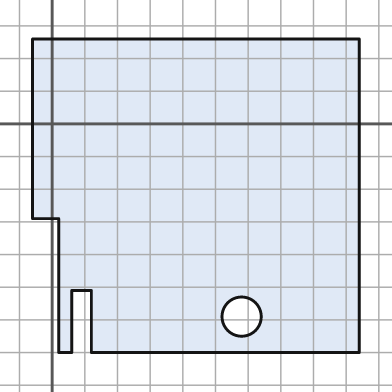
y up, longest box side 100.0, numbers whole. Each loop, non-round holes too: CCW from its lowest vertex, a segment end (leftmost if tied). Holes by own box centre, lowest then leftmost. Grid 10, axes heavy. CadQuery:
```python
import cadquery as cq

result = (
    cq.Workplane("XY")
    .moveTo(2.0, -70.0)
    .lineTo(6.0, -70.0)
    .lineTo(6.0, -51.0)
    .lineTo(12.0, -51.0)
    .lineTo(12.0, -70.0)
    .lineTo(94.0, -70.0)
    .lineTo(94.0, 26.0)
    .lineTo(-6.0, 26.0)
    .lineTo(-6.0, -29.0)
    .lineTo(2.0, -29.0)
    .close()
    .moveTo(58.0, -59.0)
    .circle(6.0)
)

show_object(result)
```